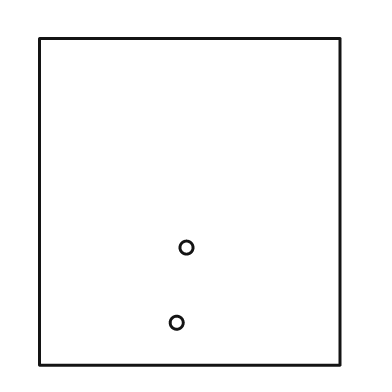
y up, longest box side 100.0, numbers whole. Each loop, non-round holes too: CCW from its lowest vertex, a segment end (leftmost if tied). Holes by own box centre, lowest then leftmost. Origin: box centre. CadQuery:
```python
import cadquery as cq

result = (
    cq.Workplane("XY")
    .moveTo(-46.0, -50.0)
    .lineTo(46.0, -50.0)
    .lineTo(46.0, 50.0)
    .lineTo(-46.0, 50.0)
    .close()
    .moveTo(-4.0, -37.0)
    .circle(2.0)
    .moveTo(-1.0, -14.0)
    .circle(2.0)
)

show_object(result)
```